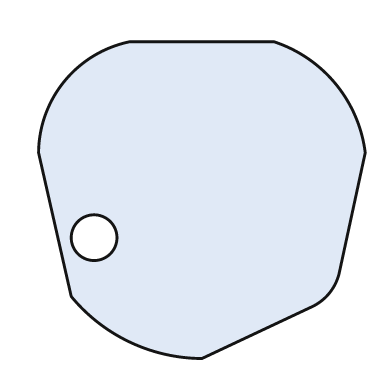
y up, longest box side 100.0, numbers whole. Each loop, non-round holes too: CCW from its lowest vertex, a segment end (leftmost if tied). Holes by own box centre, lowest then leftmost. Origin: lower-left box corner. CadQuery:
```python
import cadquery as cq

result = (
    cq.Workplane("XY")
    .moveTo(50.0, 0.0)
    .lineTo(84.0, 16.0)
    .threePointArc((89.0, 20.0), (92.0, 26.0))
    .lineTo(100.0, 63.0)
    .threePointArc((91.0, 84.0), (72.0, 97.0))
    .lineTo(28.0, 97.0)
    .threePointArc((8.0, 85.0), (0.0, 63.0))
    .lineTo(10.0, 19.0)
    .threePointArc((28.0, 5.0), (50.0, 0.0))
    .close()
    .moveTo(17.0, 37.0)
    .circle(7.0)
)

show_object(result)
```